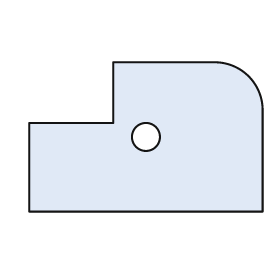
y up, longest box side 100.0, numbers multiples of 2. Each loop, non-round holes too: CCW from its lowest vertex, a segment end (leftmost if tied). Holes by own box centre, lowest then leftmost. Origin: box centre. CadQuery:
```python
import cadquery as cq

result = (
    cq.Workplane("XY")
    .moveTo(-50.0, -32.0)
    .lineTo(50.0, -32.0)
    .lineTo(50.0, 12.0)
    .threePointArc((44.0, 26.0), (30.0, 32.0))
    .lineTo(-14.0, 32.0)
    .lineTo(-14.0, 6.0)
    .lineTo(-50.0, 6.0)
    .close()
    .moveTo(0.0, 0.0)
    .circle(6.0)
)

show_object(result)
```